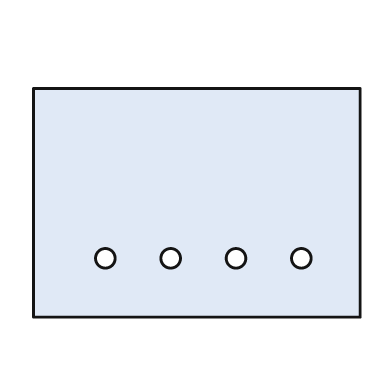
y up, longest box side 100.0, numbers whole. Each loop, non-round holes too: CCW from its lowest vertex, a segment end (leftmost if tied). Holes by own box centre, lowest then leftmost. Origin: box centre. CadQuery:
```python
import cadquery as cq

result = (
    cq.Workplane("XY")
    .moveTo(-50.0, -35.0)
    .lineTo(50.0, -35.0)
    .lineTo(50.0, 35.0)
    .lineTo(-50.0, 35.0)
    .close()
    .moveTo(-28.0, -17.0)
    .circle(3.0)
    .moveTo(-8.0, -17.0)
    .circle(3.0)
    .moveTo(12.0, -17.0)
    .circle(3.0)
    .moveTo(32.0, -17.0)
    .circle(3.0)
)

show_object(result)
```